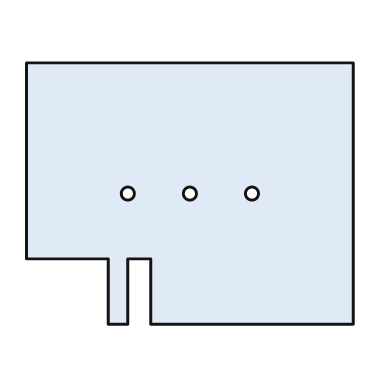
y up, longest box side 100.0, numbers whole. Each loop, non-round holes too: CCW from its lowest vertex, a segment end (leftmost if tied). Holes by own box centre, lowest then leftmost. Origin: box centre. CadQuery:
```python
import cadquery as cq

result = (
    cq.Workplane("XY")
    .moveTo(-25.0, -40.0)
    .lineTo(-19.0, -40.0)
    .lineTo(-19.0, -20.0)
    .lineTo(-12.0, -20.0)
    .lineTo(-12.0, -40.0)
    .lineTo(50.0, -40.0)
    .lineTo(50.0, 40.0)
    .lineTo(-50.0, 40.0)
    .lineTo(-50.0, -20.0)
    .lineTo(-25.0, -20.0)
    .close()
    .moveTo(-19.0, 0.0)
    .circle(2.0)
    .moveTo(0.0, 0.0)
    .circle(2.0)
    .moveTo(19.0, 0.0)
    .circle(2.0)
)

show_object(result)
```